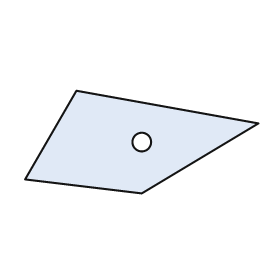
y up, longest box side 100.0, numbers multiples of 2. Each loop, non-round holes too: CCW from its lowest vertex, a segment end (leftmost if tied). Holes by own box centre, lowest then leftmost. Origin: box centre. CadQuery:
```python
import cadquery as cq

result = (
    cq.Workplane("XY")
    .moveTo(0.0, -22.0)
    .lineTo(50.0, 8.0)
    .lineTo(-28.0, 22.0)
    .lineTo(-50.0, -16.0)
    .close()
    .moveTo(0.0, 0.0)
    .circle(4.0)
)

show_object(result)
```